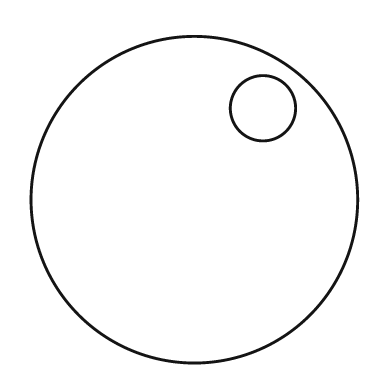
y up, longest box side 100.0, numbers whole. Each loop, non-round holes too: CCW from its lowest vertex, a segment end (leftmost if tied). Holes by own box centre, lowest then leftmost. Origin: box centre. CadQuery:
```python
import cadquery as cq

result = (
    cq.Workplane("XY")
    .moveTo(0.0, 0.0)
    .circle(50.0)
    .moveTo(21.0, 28.0)
    .circle(10.0)
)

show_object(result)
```